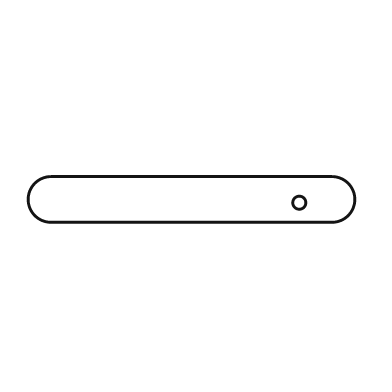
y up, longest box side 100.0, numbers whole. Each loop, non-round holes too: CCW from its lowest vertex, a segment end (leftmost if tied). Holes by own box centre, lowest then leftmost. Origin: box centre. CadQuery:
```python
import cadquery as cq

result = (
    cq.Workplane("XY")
    .moveTo(-43.0, -7.0)
    .lineTo(43.0, -7.0)
    .threePointArc((50.0, 0.0), (43.0, 7.0))
    .lineTo(-43.0, 7.0)
    .threePointArc((-50.0, 0.0), (-43.0, -7.0))
    .close()
    .moveTo(33.0, -1.0)
    .circle(2.0)
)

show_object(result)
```